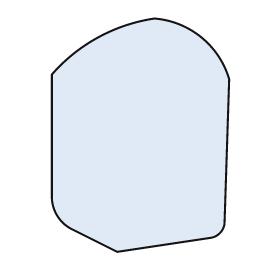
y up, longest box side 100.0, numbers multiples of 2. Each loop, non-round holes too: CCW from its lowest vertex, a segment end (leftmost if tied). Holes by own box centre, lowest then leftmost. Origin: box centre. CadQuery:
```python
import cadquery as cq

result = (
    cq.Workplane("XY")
    .moveTo(-10.0, -50.0)
    .lineTo(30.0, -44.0)
    .threePointArc((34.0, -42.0), (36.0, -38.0))
    .lineTo(38.0, 24.0)
    .threePointArc((26.0, 42.0), (6.0, 50.0))
    .threePointArc((-18.0, 42.0), (-38.0, 26.0))
    .lineTo(-38.0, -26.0)
    .threePointArc((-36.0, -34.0), (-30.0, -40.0))
    .close()
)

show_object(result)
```